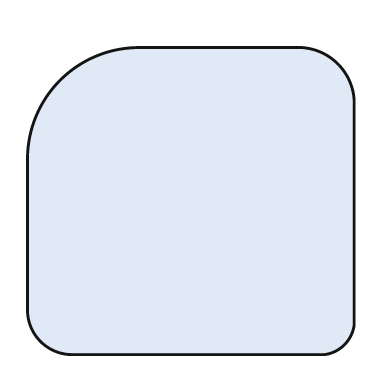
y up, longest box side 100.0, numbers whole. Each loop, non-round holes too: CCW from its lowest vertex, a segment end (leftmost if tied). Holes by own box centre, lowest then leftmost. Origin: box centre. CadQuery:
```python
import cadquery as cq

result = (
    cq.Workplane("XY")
    .moveTo(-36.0, -47.0)
    .lineTo(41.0, -47.0)
    .threePointArc((47.0, -44.0), (50.0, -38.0))
    .lineTo(50.0, 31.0)
    .threePointArc((45.0, 42.0), (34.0, 47.0))
    .lineTo(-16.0, 47.0)
    .threePointArc((-40.0, 37.0), (-50.0, 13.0))
    .lineTo(-50.0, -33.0)
    .threePointArc((-46.0, -43.0), (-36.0, -47.0))
    .close()
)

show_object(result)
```